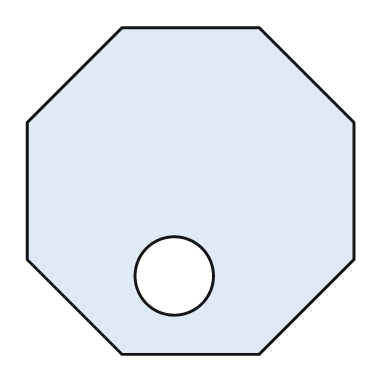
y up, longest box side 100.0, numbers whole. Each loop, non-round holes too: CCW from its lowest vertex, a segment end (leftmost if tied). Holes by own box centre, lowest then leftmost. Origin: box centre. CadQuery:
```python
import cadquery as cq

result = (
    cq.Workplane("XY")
    .moveTo(-21.0, -50.0)
    .lineTo(21.0, -50.0)
    .lineTo(50.0, -21.0)
    .lineTo(50.0, 21.0)
    .lineTo(21.0, 50.0)
    .lineTo(-21.0, 50.0)
    .lineTo(-50.0, 21.0)
    .lineTo(-50.0, -21.0)
    .close()
    .moveTo(-5.0, -26.0)
    .circle(12.0)
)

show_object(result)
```